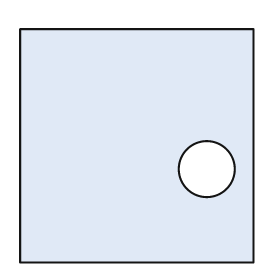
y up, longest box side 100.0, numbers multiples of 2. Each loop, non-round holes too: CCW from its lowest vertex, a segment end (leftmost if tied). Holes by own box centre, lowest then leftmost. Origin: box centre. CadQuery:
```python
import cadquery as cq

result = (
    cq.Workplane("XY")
    .moveTo(-50.0, -50.0)
    .lineTo(50.0, -50.0)
    .lineTo(50.0, 50.0)
    .lineTo(-50.0, 50.0)
    .close()
    .moveTo(30.0, -10.0)
    .circle(12.0)
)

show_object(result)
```